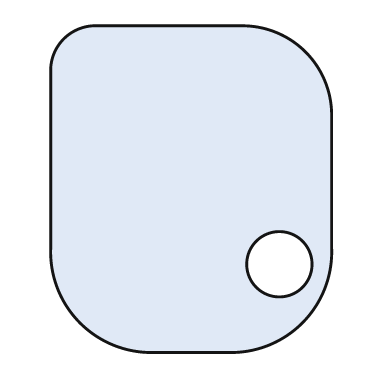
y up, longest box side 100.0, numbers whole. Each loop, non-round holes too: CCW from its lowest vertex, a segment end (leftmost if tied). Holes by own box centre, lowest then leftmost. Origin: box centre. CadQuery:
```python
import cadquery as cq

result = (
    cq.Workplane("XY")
    .moveTo(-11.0, -50.0)
    .lineTo(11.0, -50.0)
    .threePointArc((34.0, -41.0), (43.0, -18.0))
    .lineTo(43.0, 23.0)
    .threePointArc((35.0, 42.0), (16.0, 50.0))
    .lineTo(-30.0, 50.0)
    .threePointArc((-39.0, 46.0), (-43.0, 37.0))
    .lineTo(-43.0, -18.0)
    .threePointArc((-34.0, -41.0), (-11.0, -50.0))
    .close()
    .moveTo(27.0, -23.0)
    .circle(10.0)
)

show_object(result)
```